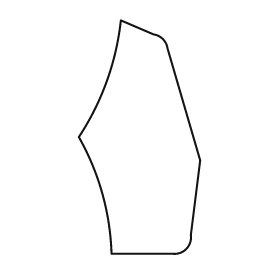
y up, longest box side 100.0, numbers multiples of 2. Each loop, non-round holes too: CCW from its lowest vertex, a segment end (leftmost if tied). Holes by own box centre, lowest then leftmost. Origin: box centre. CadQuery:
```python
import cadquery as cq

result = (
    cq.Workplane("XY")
    .moveTo(-12.0, -50.0)
    .lineTo(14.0, -50.0)
    .threePointArc((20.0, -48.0), (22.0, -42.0))
    .lineTo(26.0, -10.0)
    .lineTo(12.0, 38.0)
    .threePointArc((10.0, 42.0), (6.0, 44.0))
    .lineTo(-8.0, 50.0)
    .threePointArc((-14.0, 24.0), (-26.0, 0.0))
    .threePointArc((-16.0, -24.0), (-12.0, -50.0))
    .close()
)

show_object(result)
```